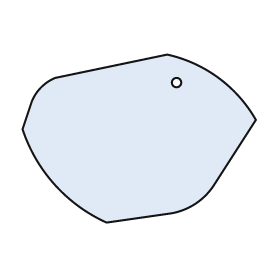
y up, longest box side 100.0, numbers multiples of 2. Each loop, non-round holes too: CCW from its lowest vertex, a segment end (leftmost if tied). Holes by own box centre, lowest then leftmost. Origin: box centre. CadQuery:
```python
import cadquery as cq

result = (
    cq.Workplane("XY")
    .moveTo(-14.0, -36.0)
    .lineTo(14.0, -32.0)
    .threePointArc((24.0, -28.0), (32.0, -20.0))
    .lineTo(50.0, 8.0)
    .threePointArc((34.0, 26.0), (12.0, 36.0))
    .lineTo(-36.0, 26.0)
    .threePointArc((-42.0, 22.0), (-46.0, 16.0))
    .lineTo(-50.0, 4.0)
    .threePointArc((-36.0, -20.0), (-14.0, -36.0))
    .close()
    .moveTo(16.0, 24.0)
    .circle(2.0)
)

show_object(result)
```